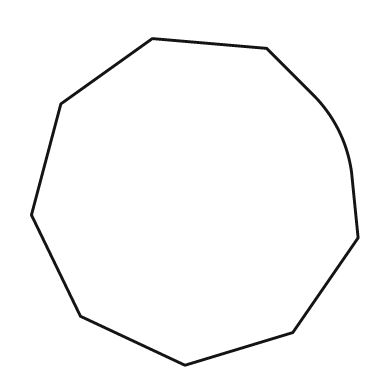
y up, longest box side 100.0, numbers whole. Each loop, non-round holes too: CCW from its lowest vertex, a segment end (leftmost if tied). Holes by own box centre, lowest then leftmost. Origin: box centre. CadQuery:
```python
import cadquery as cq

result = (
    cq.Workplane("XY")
    .moveTo(-3.0, -50.0)
    .lineTo(30.0, -40.0)
    .lineTo(50.0, -11.0)
    .lineTo(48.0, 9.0)
    .threePointArc((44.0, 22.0), (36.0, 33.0))
    .lineTo(22.0, 47.0)
    .lineTo(-13.0, 50.0)
    .lineTo(-41.0, 30.0)
    .lineTo(-50.0, -4.0)
    .lineTo(-35.0, -35.0)
    .close()
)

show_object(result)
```